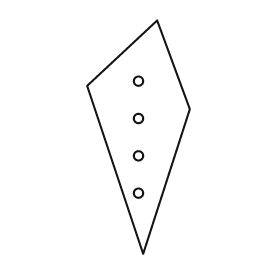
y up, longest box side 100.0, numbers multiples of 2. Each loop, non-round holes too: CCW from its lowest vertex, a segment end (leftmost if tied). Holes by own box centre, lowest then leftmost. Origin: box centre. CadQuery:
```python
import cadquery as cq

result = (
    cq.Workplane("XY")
    .moveTo(2.0, -50.0)
    .lineTo(22.0, 12.0)
    .lineTo(8.0, 50.0)
    .lineTo(-22.0, 22.0)
    .close()
    .moveTo(0.0, -24.0)
    .circle(2.0)
    .moveTo(0.0, -8.0)
    .circle(2.0)
    .moveTo(0.0, 8.0)
    .circle(2.0)
    .moveTo(0.0, 24.0)
    .circle(2.0)
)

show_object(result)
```